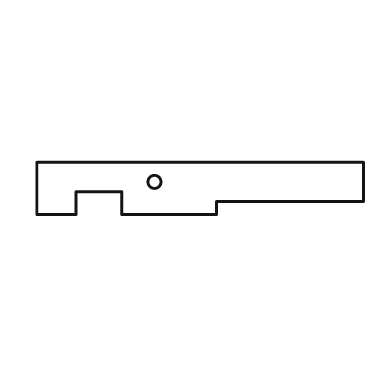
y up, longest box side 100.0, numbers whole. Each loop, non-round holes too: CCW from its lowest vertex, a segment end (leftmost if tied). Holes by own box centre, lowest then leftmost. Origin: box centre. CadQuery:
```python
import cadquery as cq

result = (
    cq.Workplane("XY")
    .moveTo(-50.0, -8.0)
    .lineTo(-38.0, -8.0)
    .lineTo(-38.0, -1.0)
    .lineTo(-24.0, -1.0)
    .lineTo(-24.0, -8.0)
    .lineTo(5.0, -8.0)
    .lineTo(5.0, -4.0)
    .lineTo(50.0, -4.0)
    .lineTo(50.0, 8.0)
    .lineTo(-50.0, 8.0)
    .close()
    .moveTo(-14.0, 2.0)
    .circle(2.0)
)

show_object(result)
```